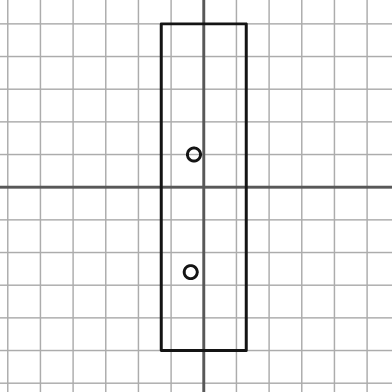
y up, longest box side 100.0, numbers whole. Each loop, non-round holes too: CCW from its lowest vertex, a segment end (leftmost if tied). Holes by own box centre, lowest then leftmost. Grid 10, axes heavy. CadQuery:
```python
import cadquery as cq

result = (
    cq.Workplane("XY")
    .moveTo(-13.0, -50.0)
    .lineTo(13.0, -50.0)
    .lineTo(13.0, 50.0)
    .lineTo(-13.0, 50.0)
    .close()
    .moveTo(-4.0, -26.0)
    .circle(2.0)
    .moveTo(-3.0, 10.0)
    .circle(2.0)
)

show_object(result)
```